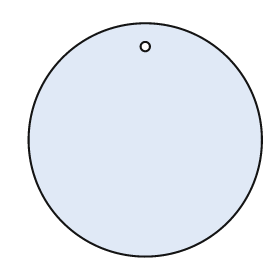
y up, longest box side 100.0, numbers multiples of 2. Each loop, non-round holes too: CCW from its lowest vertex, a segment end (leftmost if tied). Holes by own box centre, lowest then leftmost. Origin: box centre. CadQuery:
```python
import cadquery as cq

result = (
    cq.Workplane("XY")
    .moveTo(0.0, 0.0)
    .circle(50.0)
    .moveTo(0.0, 40.0)
    .circle(2.0)
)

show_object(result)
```